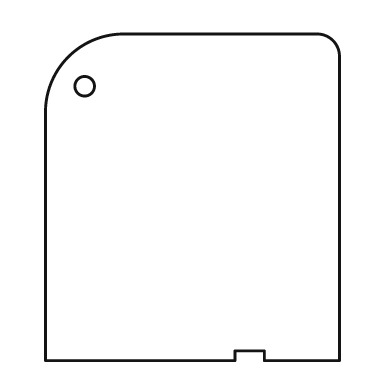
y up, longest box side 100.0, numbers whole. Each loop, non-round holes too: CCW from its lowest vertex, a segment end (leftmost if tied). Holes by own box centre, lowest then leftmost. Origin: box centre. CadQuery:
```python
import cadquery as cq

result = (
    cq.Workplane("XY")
    .moveTo(-45.0, -50.0)
    .lineTo(13.0, -50.0)
    .lineTo(13.0, -47.0)
    .lineTo(22.0, -47.0)
    .lineTo(22.0, -50.0)
    .lineTo(45.0, -50.0)
    .lineTo(45.0, 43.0)
    .threePointArc((43.0, 48.0), (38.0, 50.0))
    .lineTo(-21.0, 50.0)
    .threePointArc((-38.0, 43.0), (-45.0, 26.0))
    .close()
    .moveTo(-33.0, 34.0)
    .circle(3.0)
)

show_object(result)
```